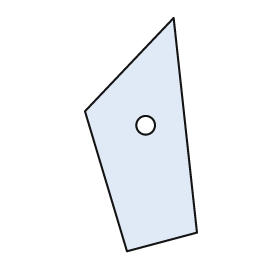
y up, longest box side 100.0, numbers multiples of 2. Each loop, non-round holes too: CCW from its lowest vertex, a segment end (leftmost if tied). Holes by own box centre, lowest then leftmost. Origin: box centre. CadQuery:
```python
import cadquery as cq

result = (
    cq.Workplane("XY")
    .moveTo(-6.0, -50.0)
    .lineTo(24.0, -42.0)
    .lineTo(14.0, 50.0)
    .lineTo(-24.0, 10.0)
    .close()
    .moveTo(2.0, 4.0)
    .circle(4.0)
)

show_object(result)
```